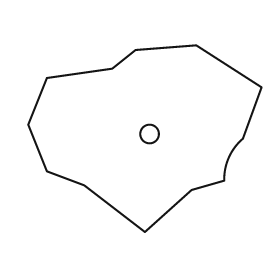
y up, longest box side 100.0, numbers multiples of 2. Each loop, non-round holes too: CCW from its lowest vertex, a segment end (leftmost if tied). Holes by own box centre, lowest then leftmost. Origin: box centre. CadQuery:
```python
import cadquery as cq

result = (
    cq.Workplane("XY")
    .moveTo(0.0, -40.0)
    .lineTo(20.0, -22.0)
    .lineTo(34.0, -18.0)
    .threePointArc((36.0, -8.0), (42.0, 0.0))
    .lineTo(50.0, 22.0)
    .lineTo(22.0, 40.0)
    .lineTo(-4.0, 38.0)
    .lineTo(-14.0, 30.0)
    .lineTo(-42.0, 26.0)
    .lineTo(-50.0, 6.0)
    .lineTo(-42.0, -14.0)
    .lineTo(-26.0, -20.0)
    .close()
    .moveTo(2.0, 2.0)
    .circle(4.0)
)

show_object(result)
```